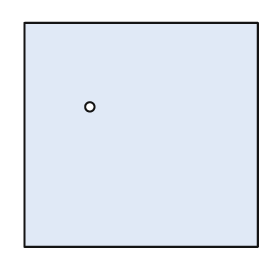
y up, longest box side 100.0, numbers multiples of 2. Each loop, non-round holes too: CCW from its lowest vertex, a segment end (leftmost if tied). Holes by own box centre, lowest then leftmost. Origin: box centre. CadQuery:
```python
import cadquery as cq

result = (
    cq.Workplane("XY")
    .moveTo(-50.0, -48.0)
    .lineTo(50.0, -48.0)
    .lineTo(50.0, 48.0)
    .lineTo(-50.0, 48.0)
    .close()
    .moveTo(-22.0, 12.0)
    .circle(2.0)
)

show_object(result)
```